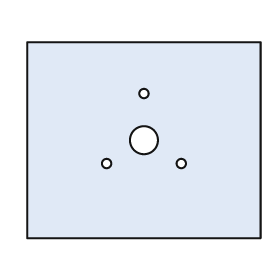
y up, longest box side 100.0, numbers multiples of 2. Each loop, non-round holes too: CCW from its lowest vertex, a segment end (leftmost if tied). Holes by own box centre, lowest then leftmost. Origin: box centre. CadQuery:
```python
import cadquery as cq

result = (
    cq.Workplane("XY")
    .moveTo(-50.0, -42.0)
    .lineTo(50.0, -42.0)
    .lineTo(50.0, 42.0)
    .lineTo(-50.0, 42.0)
    .close()
    .moveTo(-16.0, -10.0)
    .circle(2.0)
    .moveTo(16.0, -10.0)
    .circle(2.0)
    .moveTo(0.0, 0.0)
    .circle(6.0)
    .moveTo(0.0, 20.0)
    .circle(2.0)
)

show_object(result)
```